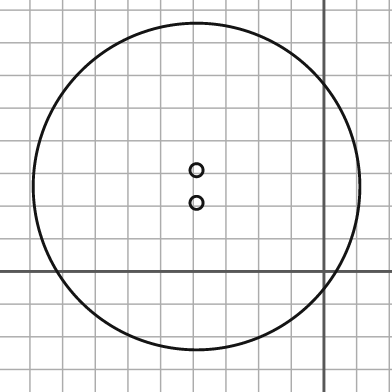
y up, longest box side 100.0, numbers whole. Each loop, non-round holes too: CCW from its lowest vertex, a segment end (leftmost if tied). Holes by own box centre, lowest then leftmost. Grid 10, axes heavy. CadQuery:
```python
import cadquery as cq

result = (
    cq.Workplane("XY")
    .moveTo(-39.0, 26.0)
    .circle(50.0)
    .moveTo(-39.0, 21.0)
    .circle(2.0)
    .moveTo(-39.0, 31.0)
    .circle(2.0)
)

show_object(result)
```